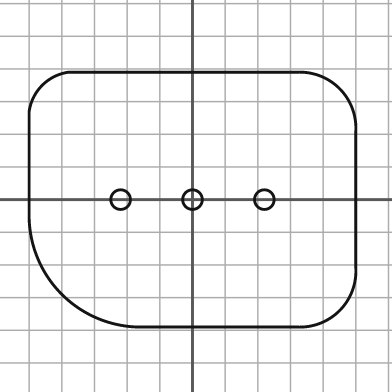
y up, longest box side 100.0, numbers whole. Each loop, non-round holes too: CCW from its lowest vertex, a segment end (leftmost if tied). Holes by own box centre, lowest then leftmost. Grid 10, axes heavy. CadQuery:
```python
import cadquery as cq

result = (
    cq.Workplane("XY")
    .moveTo(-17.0, -39.0)
    .lineTo(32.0, -39.0)
    .threePointArc((45.0, -34.0), (50.0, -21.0))
    .lineTo(50.0, 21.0)
    .threePointArc((45.0, 34.0), (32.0, 39.0))
    .lineTo(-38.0, 39.0)
    .threePointArc((-46.0, 35.0), (-50.0, 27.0))
    .lineTo(-50.0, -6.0)
    .threePointArc((-40.0, -29.0), (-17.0, -39.0))
    .close()
    .moveTo(-22.0, 0.0)
    .circle(3.0)
    .moveTo(0.0, 0.0)
    .circle(3.0)
    .moveTo(22.0, 0.0)
    .circle(3.0)
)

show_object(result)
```